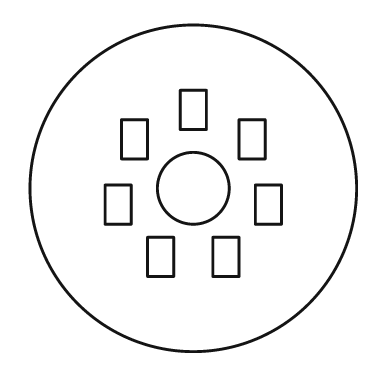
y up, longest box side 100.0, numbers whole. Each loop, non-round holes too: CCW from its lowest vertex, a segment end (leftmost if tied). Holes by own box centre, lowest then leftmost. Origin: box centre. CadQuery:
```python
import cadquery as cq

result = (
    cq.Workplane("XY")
    .moveTo(0.0, 0.0)
    .circle(50.0)
    .moveTo(-14.0, -27.0)
    .lineTo(-6.0, -27.0)
    .lineTo(-6.0, -15.0)
    .lineTo(-14.0, -15.0)
    .close()
    .moveTo(6.0, -27.0)
    .lineTo(14.0, -27.0)
    .lineTo(14.0, -15.0)
    .lineTo(6.0, -15.0)
    .close()
    .moveTo(-27.0, -11.0)
    .lineTo(-19.0, -11.0)
    .lineTo(-19.0, 1.0)
    .lineTo(-27.0, 1.0)
    .close()
    .moveTo(19.0, -11.0)
    .lineTo(27.0, -11.0)
    .lineTo(27.0, 1.0)
    .lineTo(19.0, 1.0)
    .close()
    .moveTo(0.0, 0.0)
    .circle(11.0)
    .moveTo(-22.0, 9.0)
    .lineTo(-14.0, 9.0)
    .lineTo(-14.0, 21.0)
    .lineTo(-22.0, 21.0)
    .close()
    .moveTo(14.0, 9.0)
    .lineTo(22.0, 9.0)
    .lineTo(22.0, 21.0)
    .lineTo(14.0, 21.0)
    .close()
    .moveTo(-4.0, 18.0)
    .lineTo(4.0, 18.0)
    .lineTo(4.0, 30.0)
    .lineTo(-4.0, 30.0)
    .close()
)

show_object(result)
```